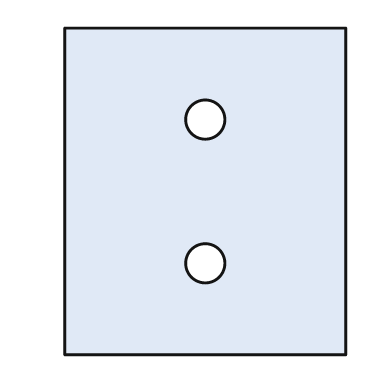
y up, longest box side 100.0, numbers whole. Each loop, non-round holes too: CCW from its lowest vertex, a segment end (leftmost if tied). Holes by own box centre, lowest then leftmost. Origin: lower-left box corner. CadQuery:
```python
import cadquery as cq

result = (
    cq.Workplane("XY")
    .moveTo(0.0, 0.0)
    .lineTo(86.0, 0.0)
    .lineTo(86.0, 100.0)
    .lineTo(0.0, 100.0)
    .close()
    .moveTo(43.0, 28.0)
    .circle(6.0)
    .moveTo(43.0, 72.0)
    .circle(6.0)
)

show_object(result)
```